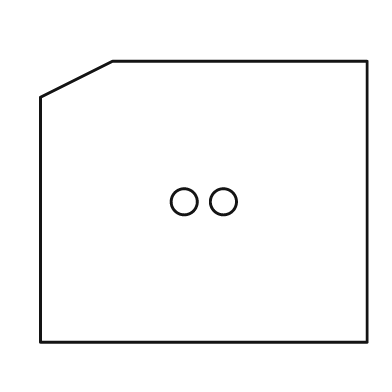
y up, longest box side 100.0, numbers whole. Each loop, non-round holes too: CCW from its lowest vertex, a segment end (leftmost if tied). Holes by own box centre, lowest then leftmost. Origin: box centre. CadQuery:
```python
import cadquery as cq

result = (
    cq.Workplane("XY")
    .moveTo(-50.0, -43.0)
    .lineTo(50.0, -43.0)
    .lineTo(50.0, 43.0)
    .lineTo(-28.0, 43.0)
    .lineTo(-50.0, 32.0)
    .close()
    .moveTo(-6.0, 0.0)
    .circle(4.0)
    .moveTo(6.0, 0.0)
    .circle(4.0)
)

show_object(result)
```